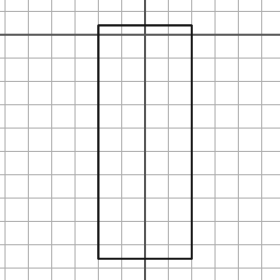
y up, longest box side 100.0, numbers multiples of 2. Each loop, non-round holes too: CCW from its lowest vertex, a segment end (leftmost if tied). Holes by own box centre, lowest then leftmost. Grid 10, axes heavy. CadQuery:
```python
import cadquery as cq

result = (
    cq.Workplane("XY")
    .moveTo(-20.0, -96.0)
    .lineTo(20.0, -96.0)
    .lineTo(20.0, 4.0)
    .lineTo(-20.0, 4.0)
    .close()
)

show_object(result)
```